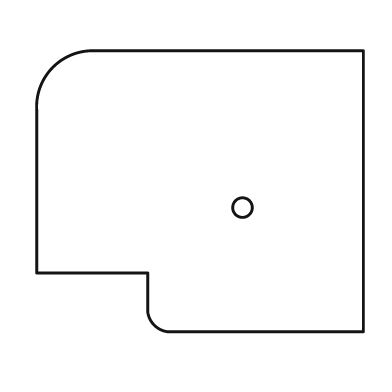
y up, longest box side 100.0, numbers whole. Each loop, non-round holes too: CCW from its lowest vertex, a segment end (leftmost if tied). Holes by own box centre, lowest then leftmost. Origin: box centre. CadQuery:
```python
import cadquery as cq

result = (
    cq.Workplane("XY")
    .moveTo(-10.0, -43.0)
    .lineTo(50.0, -43.0)
    .lineTo(50.0, 43.0)
    .lineTo(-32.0, 43.0)
    .threePointArc((-45.0, 38.0), (-50.0, 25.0))
    .lineTo(-50.0, -25.0)
    .lineTo(-16.0, -25.0)
    .lineTo(-16.0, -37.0)
    .threePointArc((-14.0, -41.0), (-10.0, -43.0))
    .close()
    .moveTo(13.0, -5.0)
    .circle(3.0)
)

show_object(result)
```